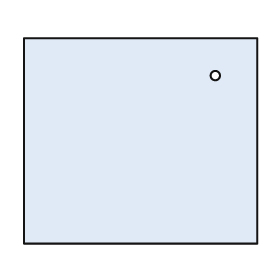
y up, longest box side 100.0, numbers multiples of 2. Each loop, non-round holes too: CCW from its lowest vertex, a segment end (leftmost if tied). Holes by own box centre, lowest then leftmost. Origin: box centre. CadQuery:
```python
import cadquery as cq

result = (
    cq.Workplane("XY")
    .moveTo(-50.0, -44.0)
    .lineTo(50.0, -44.0)
    .lineTo(50.0, 44.0)
    .lineTo(-50.0, 44.0)
    .close()
    .moveTo(32.0, 28.0)
    .circle(2.0)
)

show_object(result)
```